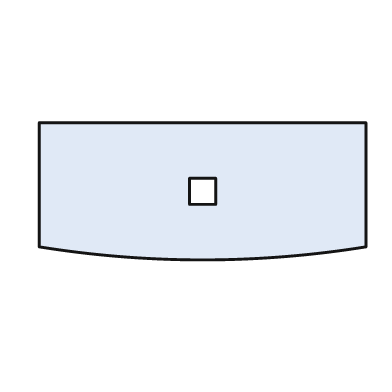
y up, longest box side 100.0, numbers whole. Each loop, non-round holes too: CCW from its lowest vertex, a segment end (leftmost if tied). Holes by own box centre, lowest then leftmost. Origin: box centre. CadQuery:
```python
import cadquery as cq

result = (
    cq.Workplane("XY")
    .moveTo(-50.0, -17.0)
    .threePointArc((0.0, -21.0), (50.0, -17.0))
    .lineTo(50.0, 21.0)
    .lineTo(-50.0, 21.0)
    .close()
    .moveTo(-4.0, -4.0)
    .lineTo(4.0, -4.0)
    .lineTo(4.0, 4.0)
    .lineTo(-4.0, 4.0)
    .close()
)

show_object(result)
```